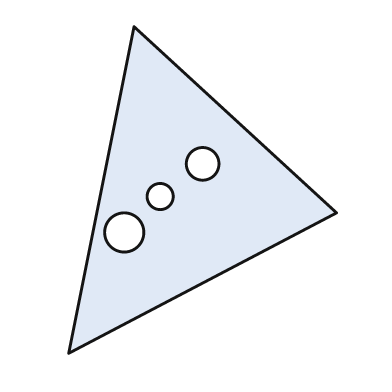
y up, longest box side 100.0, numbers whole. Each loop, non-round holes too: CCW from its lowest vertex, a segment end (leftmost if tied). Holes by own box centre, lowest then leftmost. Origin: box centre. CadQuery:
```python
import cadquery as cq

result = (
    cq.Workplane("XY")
    .moveTo(-41.0, -50.0)
    .lineTo(41.0, -7.0)
    .lineTo(-21.0, 50.0)
    .close()
    .moveTo(-24.0, -13.0)
    .circle(6.0)
    .moveTo(-13.0, -2.0)
    .circle(4.0)
    .moveTo(0.0, 8.0)
    .circle(5.0)
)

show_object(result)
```